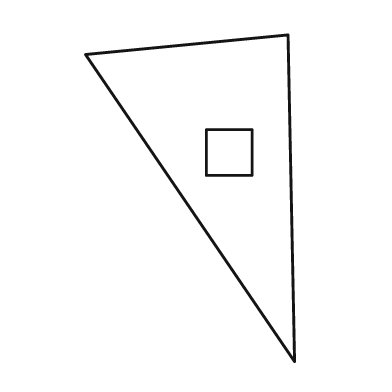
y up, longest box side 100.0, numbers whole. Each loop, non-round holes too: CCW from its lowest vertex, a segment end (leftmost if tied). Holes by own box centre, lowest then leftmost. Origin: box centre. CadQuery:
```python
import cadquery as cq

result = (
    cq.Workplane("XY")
    .moveTo(32.0, -50.0)
    .lineTo(30.0, 50.0)
    .lineTo(-32.0, 44.0)
    .close()
    .moveTo(5.0, 7.0)
    .lineTo(19.0, 7.0)
    .lineTo(19.0, 21.0)
    .lineTo(5.0, 21.0)
    .close()
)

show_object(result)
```